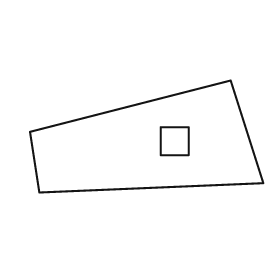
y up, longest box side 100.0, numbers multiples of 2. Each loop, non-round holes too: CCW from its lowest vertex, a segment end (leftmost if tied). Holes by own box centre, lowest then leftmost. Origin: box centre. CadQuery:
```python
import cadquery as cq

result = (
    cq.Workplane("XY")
    .moveTo(-46.0, -24.0)
    .lineTo(50.0, -20.0)
    .lineTo(36.0, 24.0)
    .lineTo(-50.0, 2.0)
    .close()
    .moveTo(6.0, -8.0)
    .lineTo(18.0, -8.0)
    .lineTo(18.0, 4.0)
    .lineTo(6.0, 4.0)
    .close()
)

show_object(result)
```